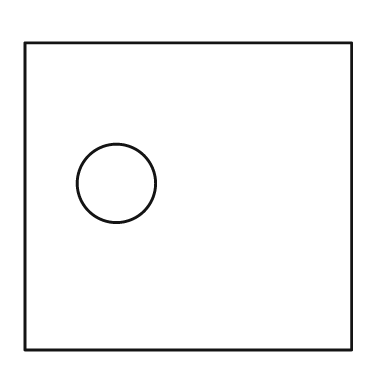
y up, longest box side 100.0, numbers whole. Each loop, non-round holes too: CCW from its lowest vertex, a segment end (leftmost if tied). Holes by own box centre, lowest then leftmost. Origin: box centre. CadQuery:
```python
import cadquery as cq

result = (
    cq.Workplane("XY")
    .moveTo(-50.0, -47.0)
    .lineTo(50.0, -47.0)
    .lineTo(50.0, 47.0)
    .lineTo(-50.0, 47.0)
    .close()
    .moveTo(-22.0, 4.0)
    .circle(12.0)
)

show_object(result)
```